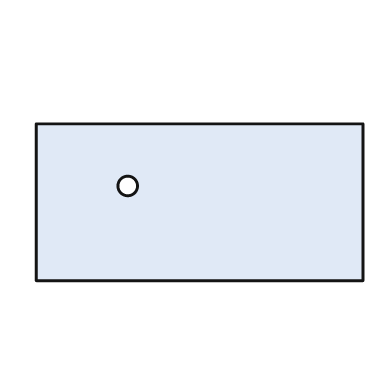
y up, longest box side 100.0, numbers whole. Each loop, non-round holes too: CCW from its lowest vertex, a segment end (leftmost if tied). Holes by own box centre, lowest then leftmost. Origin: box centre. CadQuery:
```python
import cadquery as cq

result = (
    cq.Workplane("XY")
    .moveTo(-50.0, -24.0)
    .lineTo(50.0, -24.0)
    .lineTo(50.0, 24.0)
    .lineTo(-50.0, 24.0)
    .close()
    .moveTo(-22.0, 5.0)
    .circle(3.0)
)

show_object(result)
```